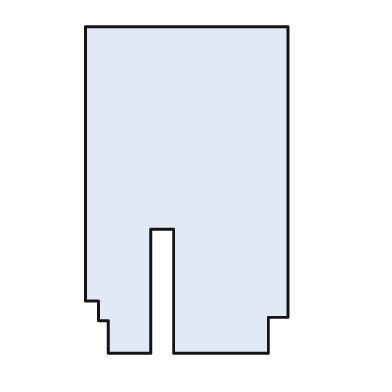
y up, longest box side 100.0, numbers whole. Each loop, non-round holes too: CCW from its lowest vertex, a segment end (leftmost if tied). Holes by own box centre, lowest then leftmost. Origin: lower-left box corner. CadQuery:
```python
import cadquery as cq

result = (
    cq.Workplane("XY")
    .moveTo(7.0, 0.0)
    .lineTo(20.0, 0.0)
    .lineTo(20.0, 38.0)
    .lineTo(27.0, 38.0)
    .lineTo(27.0, 0.0)
    .lineTo(56.0, 0.0)
    .lineTo(56.0, 11.0)
    .lineTo(62.0, 11.0)
    .lineTo(62.0, 100.0)
    .lineTo(0.0, 100.0)
    .lineTo(0.0, 16.0)
    .lineTo(4.0, 16.0)
    .lineTo(4.0, 10.0)
    .lineTo(7.0, 10.0)
    .close()
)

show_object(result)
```